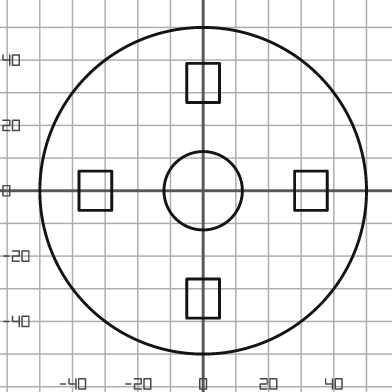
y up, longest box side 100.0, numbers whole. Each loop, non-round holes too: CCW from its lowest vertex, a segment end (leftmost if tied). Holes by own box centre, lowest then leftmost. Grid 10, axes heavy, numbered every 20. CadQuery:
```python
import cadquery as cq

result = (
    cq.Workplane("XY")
    .moveTo(0.0, 0.0)
    .circle(50.0)
    .moveTo(-5.0, -39.0)
    .lineTo(5.0, -39.0)
    .lineTo(5.0, -27.0)
    .lineTo(-5.0, -27.0)
    .close()
    .moveTo(-38.0, -6.0)
    .lineTo(-28.0, -6.0)
    .lineTo(-28.0, 6.0)
    .lineTo(-38.0, 6.0)
    .close()
    .moveTo(0.0, 0.0)
    .circle(12.0)
    .moveTo(28.0, -6.0)
    .lineTo(38.0, -6.0)
    .lineTo(38.0, 6.0)
    .lineTo(28.0, 6.0)
    .close()
    .moveTo(-5.0, 27.0)
    .lineTo(5.0, 27.0)
    .lineTo(5.0, 39.0)
    .lineTo(-5.0, 39.0)
    .close()
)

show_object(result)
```